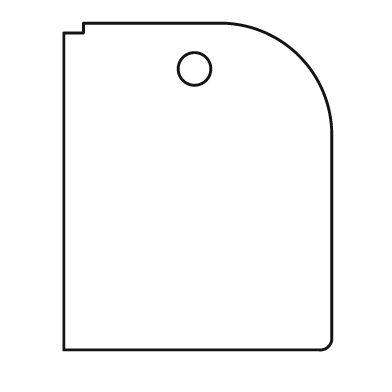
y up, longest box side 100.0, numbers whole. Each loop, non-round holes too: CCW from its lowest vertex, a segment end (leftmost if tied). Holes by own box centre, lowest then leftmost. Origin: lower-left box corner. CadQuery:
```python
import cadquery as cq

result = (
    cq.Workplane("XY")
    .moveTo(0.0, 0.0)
    .lineTo(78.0, 0.0)
    .threePointArc((81.0, 1.0), (82.0, 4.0))
    .lineTo(82.0, 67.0)
    .threePointArc((72.0, 90.0), (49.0, 100.0))
    .lineTo(6.0, 100.0)
    .lineTo(6.0, 97.0)
    .lineTo(0.0, 97.0)
    .close()
    .moveTo(40.0, 86.0)
    .circle(5.0)
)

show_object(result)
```